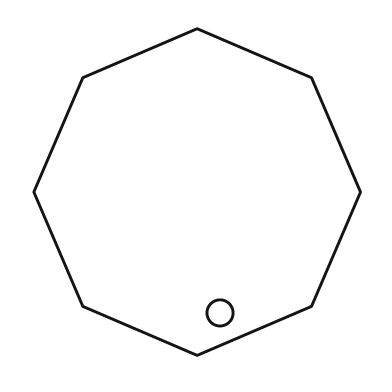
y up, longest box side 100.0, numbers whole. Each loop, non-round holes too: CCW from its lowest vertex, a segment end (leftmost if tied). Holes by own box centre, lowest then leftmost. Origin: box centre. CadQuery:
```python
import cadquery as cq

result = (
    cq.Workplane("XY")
    .moveTo(0.0, -50.0)
    .lineTo(35.0, -35.0)
    .lineTo(50.0, 0.0)
    .lineTo(35.0, 35.0)
    .lineTo(0.0, 50.0)
    .lineTo(-35.0, 35.0)
    .lineTo(-50.0, 0.0)
    .lineTo(-35.0, -35.0)
    .close()
    .moveTo(7.0, -37.0)
    .circle(4.0)
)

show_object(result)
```